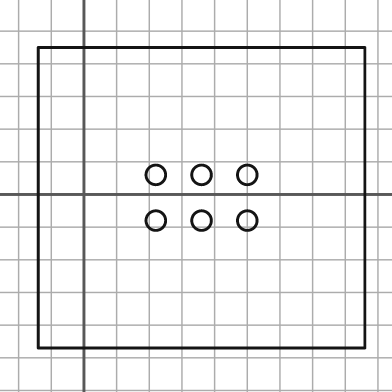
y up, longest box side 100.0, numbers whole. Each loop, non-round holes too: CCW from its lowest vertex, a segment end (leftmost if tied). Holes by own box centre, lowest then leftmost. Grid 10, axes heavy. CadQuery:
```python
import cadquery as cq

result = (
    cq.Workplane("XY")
    .moveTo(-14.0, -47.0)
    .lineTo(86.0, -47.0)
    .lineTo(86.0, 45.0)
    .lineTo(-14.0, 45.0)
    .close()
    .moveTo(22.0, -8.0)
    .circle(3.0)
    .moveTo(36.0, -8.0)
    .circle(3.0)
    .moveTo(50.0, -8.0)
    .circle(3.0)
    .moveTo(22.0, 6.0)
    .circle(3.0)
    .moveTo(36.0, 6.0)
    .circle(3.0)
    .moveTo(50.0, 6.0)
    .circle(3.0)
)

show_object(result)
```